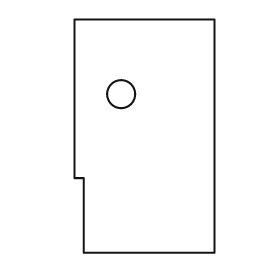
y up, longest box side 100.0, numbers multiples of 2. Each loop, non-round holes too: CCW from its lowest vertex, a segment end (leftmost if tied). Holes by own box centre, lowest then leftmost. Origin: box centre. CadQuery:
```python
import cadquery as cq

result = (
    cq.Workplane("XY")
    .moveTo(-26.0, -50.0)
    .lineTo(30.0, -50.0)
    .lineTo(30.0, 50.0)
    .lineTo(-30.0, 50.0)
    .lineTo(-30.0, -18.0)
    .lineTo(-26.0, -18.0)
    .close()
    .moveTo(-10.0, 18.0)
    .circle(6.0)
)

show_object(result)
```